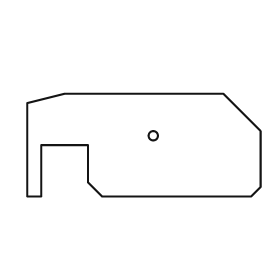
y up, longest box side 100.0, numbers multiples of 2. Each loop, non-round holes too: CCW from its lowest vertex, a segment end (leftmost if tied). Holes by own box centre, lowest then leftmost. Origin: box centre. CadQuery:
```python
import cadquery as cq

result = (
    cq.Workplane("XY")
    .moveTo(-50.0, -22.0)
    .lineTo(-44.0, -22.0)
    .lineTo(-44.0, 0.0)
    .lineTo(-24.0, 0.0)
    .lineTo(-24.0, -16.0)
    .lineTo(-18.0, -22.0)
    .lineTo(46.0, -22.0)
    .lineTo(50.0, -18.0)
    .lineTo(50.0, 6.0)
    .lineTo(34.0, 22.0)
    .lineTo(-34.0, 22.0)
    .lineTo(-50.0, 18.0)
    .close()
    .moveTo(4.0, 4.0)
    .circle(2.0)
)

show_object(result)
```